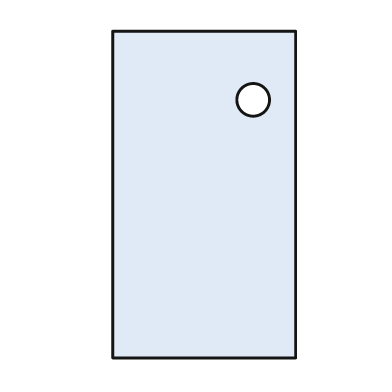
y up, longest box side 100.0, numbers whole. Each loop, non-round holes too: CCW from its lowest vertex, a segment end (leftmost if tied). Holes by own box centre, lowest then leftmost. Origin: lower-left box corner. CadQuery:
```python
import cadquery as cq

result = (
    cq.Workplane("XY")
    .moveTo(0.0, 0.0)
    .lineTo(56.0, 0.0)
    .lineTo(56.0, 100.0)
    .lineTo(0.0, 100.0)
    .close()
    .moveTo(43.0, 79.0)
    .circle(5.0)
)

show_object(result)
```